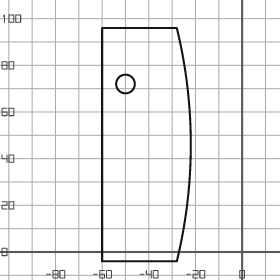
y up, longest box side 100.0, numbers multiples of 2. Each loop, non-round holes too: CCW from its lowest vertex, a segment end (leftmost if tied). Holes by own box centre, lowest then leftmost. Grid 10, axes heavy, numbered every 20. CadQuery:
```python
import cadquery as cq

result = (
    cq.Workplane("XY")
    .moveTo(-60.0, -4.0)
    .lineTo(-28.0, -4.0)
    .threePointArc((-22.0, 46.0), (-28.0, 96.0))
    .lineTo(-60.0, 96.0)
    .close()
    .moveTo(-50.0, 72.0)
    .circle(4.0)
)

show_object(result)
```